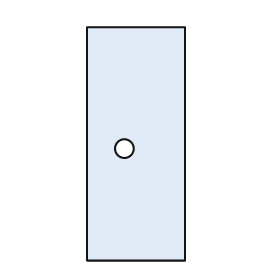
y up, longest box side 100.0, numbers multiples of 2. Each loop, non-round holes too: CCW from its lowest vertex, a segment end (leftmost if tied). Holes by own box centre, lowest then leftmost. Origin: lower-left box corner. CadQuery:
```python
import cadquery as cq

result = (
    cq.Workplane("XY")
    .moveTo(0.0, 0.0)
    .lineTo(42.0, 0.0)
    .lineTo(42.0, 100.0)
    .lineTo(0.0, 100.0)
    .close()
    .moveTo(16.0, 48.0)
    .circle(4.0)
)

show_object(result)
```